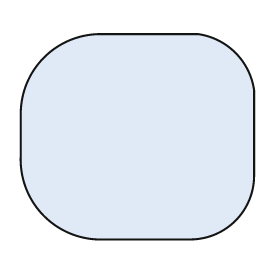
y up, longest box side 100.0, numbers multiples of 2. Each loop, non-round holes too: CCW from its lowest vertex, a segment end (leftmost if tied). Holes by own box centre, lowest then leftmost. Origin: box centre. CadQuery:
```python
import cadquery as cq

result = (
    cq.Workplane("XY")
    .moveTo(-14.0, -44.0)
    .lineTo(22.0, -44.0)
    .threePointArc((42.0, -36.0), (50.0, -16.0))
    .lineTo(50.0, 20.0)
    .threePointArc((42.0, 36.0), (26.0, 44.0))
    .lineTo(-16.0, 44.0)
    .threePointArc((-40.0, 34.0), (-50.0, 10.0))
    .lineTo(-50.0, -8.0)
    .threePointArc((-40.0, -34.0), (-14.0, -44.0))
    .close()
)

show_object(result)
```